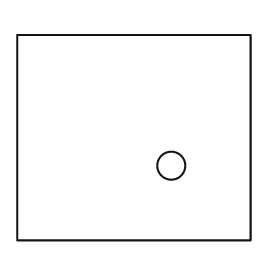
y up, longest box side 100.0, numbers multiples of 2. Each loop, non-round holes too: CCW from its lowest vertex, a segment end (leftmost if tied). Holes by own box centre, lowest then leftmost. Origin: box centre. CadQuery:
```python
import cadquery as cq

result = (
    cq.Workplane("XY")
    .moveTo(-50.0, -44.0)
    .lineTo(50.0, -44.0)
    .lineTo(50.0, 44.0)
    .lineTo(-50.0, 44.0)
    .close()
    .moveTo(16.0, -12.0)
    .circle(6.0)
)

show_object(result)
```